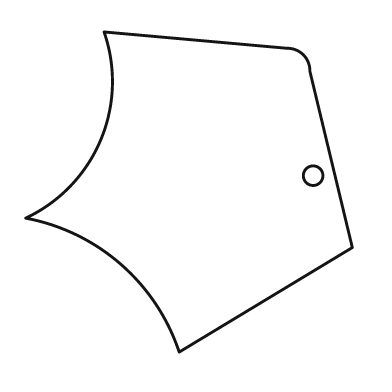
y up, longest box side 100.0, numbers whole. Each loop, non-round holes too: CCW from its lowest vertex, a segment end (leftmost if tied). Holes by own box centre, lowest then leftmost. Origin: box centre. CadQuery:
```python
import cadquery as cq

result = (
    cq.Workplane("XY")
    .moveTo(-3.0, -49.0)
    .lineTo(50.0, -17.0)
    .lineTo(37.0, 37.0)
    .threePointArc((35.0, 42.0), (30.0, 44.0))
    .lineTo(-26.0, 49.0)
    .threePointArc((-27.0, 16.0), (-50.0, -8.0))
    .threePointArc((-21.0, -22.0), (-3.0, -49.0))
    .close()
    .moveTo(38.0, 5.0)
    .circle(3.0)
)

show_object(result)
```